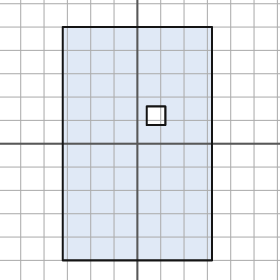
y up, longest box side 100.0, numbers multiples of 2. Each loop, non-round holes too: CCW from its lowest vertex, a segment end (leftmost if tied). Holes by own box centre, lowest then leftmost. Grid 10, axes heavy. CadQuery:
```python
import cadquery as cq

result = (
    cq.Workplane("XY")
    .moveTo(-32.0, -50.0)
    .lineTo(32.0, -50.0)
    .lineTo(32.0, 50.0)
    .lineTo(-32.0, 50.0)
    .close()
    .moveTo(4.0, 8.0)
    .lineTo(12.0, 8.0)
    .lineTo(12.0, 16.0)
    .lineTo(4.0, 16.0)
    .close()
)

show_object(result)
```